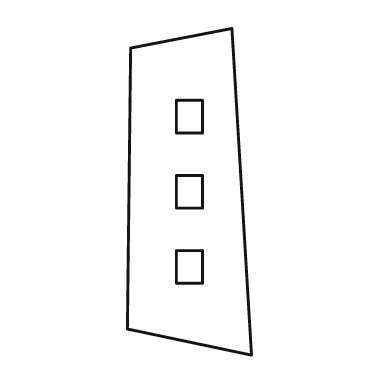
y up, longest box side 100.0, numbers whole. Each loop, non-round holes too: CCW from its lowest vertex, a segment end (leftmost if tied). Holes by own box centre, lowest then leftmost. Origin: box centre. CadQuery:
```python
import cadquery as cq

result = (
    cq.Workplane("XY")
    .moveTo(19.0, -50.0)
    .lineTo(13.0, 50.0)
    .lineTo(-18.0, 44.0)
    .lineTo(-19.0, -42.0)
    .close()
    .moveTo(-4.0, -28.0)
    .lineTo(4.0, -28.0)
    .lineTo(4.0, -18.0)
    .lineTo(-4.0, -18.0)
    .close()
    .moveTo(-4.0, -5.0)
    .lineTo(4.0, -5.0)
    .lineTo(4.0, 5.0)
    .lineTo(-4.0, 5.0)
    .close()
    .moveTo(-4.0, 18.0)
    .lineTo(4.0, 18.0)
    .lineTo(4.0, 28.0)
    .lineTo(-4.0, 28.0)
    .close()
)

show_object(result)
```